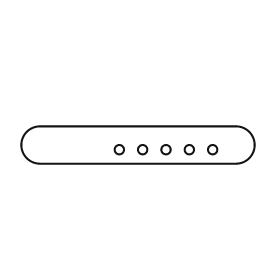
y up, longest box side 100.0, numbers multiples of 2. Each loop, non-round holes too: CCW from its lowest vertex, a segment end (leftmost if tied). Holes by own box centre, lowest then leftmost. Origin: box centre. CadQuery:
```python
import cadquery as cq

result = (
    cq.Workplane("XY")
    .moveTo(-42.0, -8.0)
    .lineTo(42.0, -8.0)
    .threePointArc((50.0, 0.0), (42.0, 8.0))
    .lineTo(-42.0, 8.0)
    .threePointArc((-50.0, 0.0), (-42.0, -8.0))
    .close()
    .moveTo(-8.0, -2.0)
    .circle(2.0)
    .moveTo(2.0, -2.0)
    .circle(2.0)
    .moveTo(12.0, -2.0)
    .circle(2.0)
    .moveTo(22.0, -2.0)
    .circle(2.0)
    .moveTo(32.0, -2.0)
    .circle(2.0)
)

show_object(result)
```